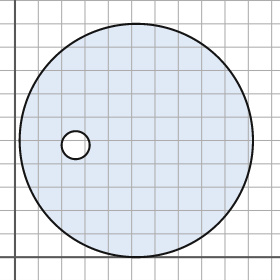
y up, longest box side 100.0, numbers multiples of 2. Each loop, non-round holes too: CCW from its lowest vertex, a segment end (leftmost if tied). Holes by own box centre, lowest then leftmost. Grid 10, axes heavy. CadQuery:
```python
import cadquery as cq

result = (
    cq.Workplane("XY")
    .moveTo(52.0, 50.0)
    .circle(50.0)
    .moveTo(26.0, 48.0)
    .circle(6.0)
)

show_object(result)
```